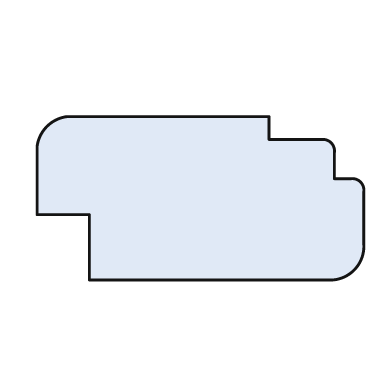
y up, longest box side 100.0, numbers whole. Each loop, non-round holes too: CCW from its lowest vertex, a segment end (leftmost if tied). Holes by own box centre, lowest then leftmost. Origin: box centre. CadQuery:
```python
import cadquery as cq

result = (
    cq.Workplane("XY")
    .moveTo(-34.0, -25.0)
    .lineTo(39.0, -25.0)
    .threePointArc((47.0, -22.0), (50.0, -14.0))
    .lineTo(50.0, 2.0)
    .threePointArc((49.0, 5.0), (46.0, 6.0))
    .lineTo(41.0, 6.0)
    .lineTo(41.0, 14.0)
    .threePointArc((40.0, 17.0), (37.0, 18.0))
    .lineTo(21.0, 18.0)
    .lineTo(21.0, 25.0)
    .lineTo(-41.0, 25.0)
    .threePointArc((-47.0, 22.0), (-50.0, 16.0))
    .lineTo(-50.0, -5.0)
    .lineTo(-34.0, -5.0)
    .close()
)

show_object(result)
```